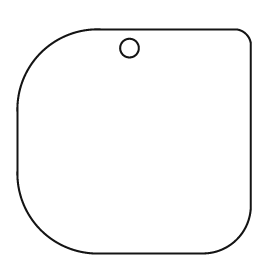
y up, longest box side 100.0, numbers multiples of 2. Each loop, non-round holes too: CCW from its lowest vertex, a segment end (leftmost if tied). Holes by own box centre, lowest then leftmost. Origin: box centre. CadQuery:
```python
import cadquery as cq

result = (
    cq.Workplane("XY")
    .moveTo(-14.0, -48.0)
    .lineTo(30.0, -48.0)
    .threePointArc((44.0, -42.0), (50.0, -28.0))
    .lineTo(50.0, 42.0)
    .threePointArc((48.0, 46.0), (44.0, 48.0))
    .lineTo(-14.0, 48.0)
    .threePointArc((-40.0, 38.0), (-50.0, 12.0))
    .lineTo(-50.0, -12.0)
    .threePointArc((-40.0, -38.0), (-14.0, -48.0))
    .close()
    .moveTo(-2.0, 40.0)
    .circle(4.0)
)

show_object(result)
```